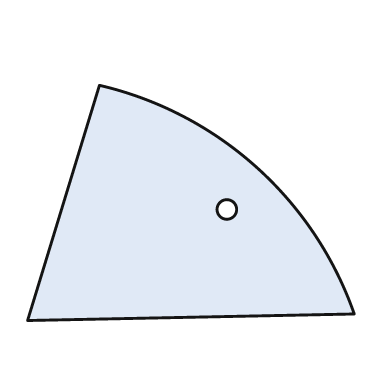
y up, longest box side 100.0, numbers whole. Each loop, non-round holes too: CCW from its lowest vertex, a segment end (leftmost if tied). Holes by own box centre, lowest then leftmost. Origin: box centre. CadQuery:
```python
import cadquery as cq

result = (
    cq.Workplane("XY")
    .moveTo(-50.0, -36.0)
    .lineTo(50.0, -34.0)
    .threePointArc((20.0, 11.0), (-28.0, 36.0))
    .close()
    .moveTo(11.0, -2.0)
    .circle(3.0)
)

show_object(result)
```